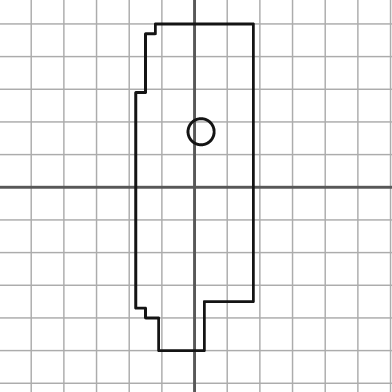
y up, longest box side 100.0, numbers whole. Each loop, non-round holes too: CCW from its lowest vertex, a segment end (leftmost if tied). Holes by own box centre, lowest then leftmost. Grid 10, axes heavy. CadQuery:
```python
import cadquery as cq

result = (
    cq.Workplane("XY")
    .moveTo(-11.0, -50.0)
    .lineTo(3.0, -50.0)
    .lineTo(3.0, -35.0)
    .lineTo(18.0, -35.0)
    .lineTo(18.0, 50.0)
    .lineTo(-12.0, 50.0)
    .lineTo(-12.0, 47.0)
    .lineTo(-15.0, 47.0)
    .lineTo(-15.0, 29.0)
    .lineTo(-18.0, 29.0)
    .lineTo(-18.0, -37.0)
    .lineTo(-15.0, -37.0)
    .lineTo(-15.0, -40.0)
    .lineTo(-11.0, -40.0)
    .close()
    .moveTo(2.0, 17.0)
    .circle(4.0)
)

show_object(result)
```